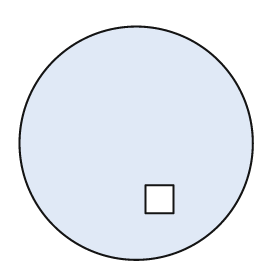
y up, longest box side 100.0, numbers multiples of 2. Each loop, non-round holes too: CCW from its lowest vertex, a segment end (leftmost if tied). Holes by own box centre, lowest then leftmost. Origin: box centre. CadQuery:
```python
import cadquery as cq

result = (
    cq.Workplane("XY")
    .moveTo(0.0, 0.0)
    .circle(50.0)
    .moveTo(4.0, -30.0)
    .lineTo(16.0, -30.0)
    .lineTo(16.0, -18.0)
    .lineTo(4.0, -18.0)
    .close()
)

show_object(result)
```